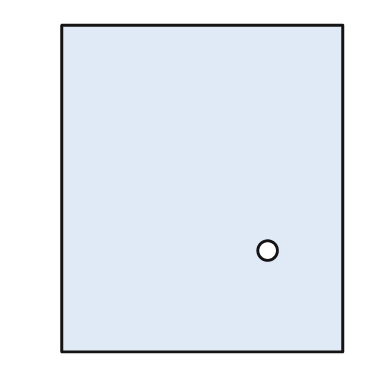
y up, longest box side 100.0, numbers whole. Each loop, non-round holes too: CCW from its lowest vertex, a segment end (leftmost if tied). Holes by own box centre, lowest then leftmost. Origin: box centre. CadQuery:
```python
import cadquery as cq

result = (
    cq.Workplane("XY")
    .moveTo(-43.0, -50.0)
    .lineTo(43.0, -50.0)
    .lineTo(43.0, 50.0)
    .lineTo(-43.0, 50.0)
    .close()
    .moveTo(20.0, -19.0)
    .circle(3.0)
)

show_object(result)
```